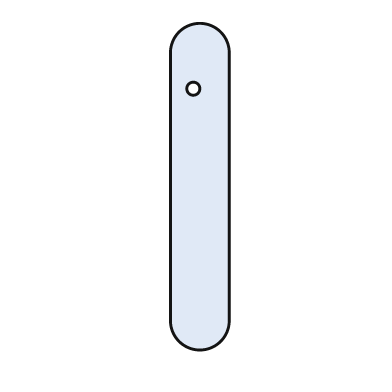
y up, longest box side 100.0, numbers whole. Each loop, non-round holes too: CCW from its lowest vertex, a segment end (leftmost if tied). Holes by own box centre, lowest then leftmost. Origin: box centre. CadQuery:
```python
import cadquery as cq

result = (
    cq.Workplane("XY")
    .moveTo(-9.0, -41.0)
    .threePointArc((0.0, -50.0), (9.0, -41.0))
    .lineTo(9.0, 41.0)
    .threePointArc((0.0, 50.0), (-9.0, 41.0))
    .close()
    .moveTo(-2.0, 30.0)
    .circle(2.0)
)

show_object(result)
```